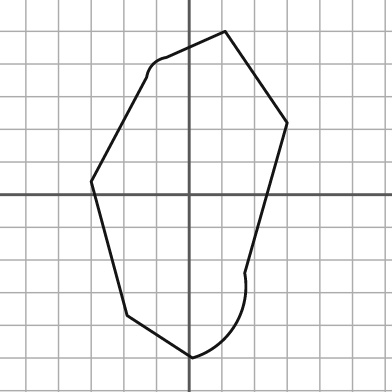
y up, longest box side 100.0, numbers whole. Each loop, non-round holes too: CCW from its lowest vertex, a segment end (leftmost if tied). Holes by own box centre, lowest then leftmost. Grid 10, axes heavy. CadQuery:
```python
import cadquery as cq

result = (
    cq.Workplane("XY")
    .moveTo(1.0, -50.0)
    .threePointArc((14.0, -40.0), (17.0, -24.0))
    .lineTo(30.0, 22.0)
    .lineTo(11.0, 50.0)
    .lineTo(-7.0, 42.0)
    .threePointArc((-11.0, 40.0), (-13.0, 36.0))
    .lineTo(-30.0, 4.0)
    .lineTo(-19.0, -37.0)
    .close()
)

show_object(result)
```